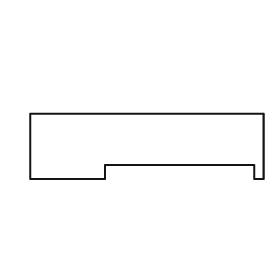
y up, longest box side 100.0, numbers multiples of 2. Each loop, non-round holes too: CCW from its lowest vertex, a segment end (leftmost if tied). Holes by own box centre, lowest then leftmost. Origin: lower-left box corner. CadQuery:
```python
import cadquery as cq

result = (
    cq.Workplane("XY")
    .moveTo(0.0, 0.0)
    .lineTo(32.0, 0.0)
    .lineTo(32.0, 6.0)
    .lineTo(96.0, 6.0)
    .lineTo(96.0, 0.0)
    .lineTo(100.0, 0.0)
    .lineTo(100.0, 28.0)
    .lineTo(0.0, 28.0)
    .close()
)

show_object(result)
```